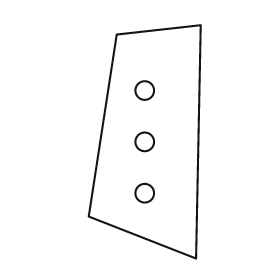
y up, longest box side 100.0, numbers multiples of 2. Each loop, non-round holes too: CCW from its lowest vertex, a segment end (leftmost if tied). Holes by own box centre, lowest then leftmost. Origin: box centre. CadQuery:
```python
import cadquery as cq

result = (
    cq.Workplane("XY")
    .moveTo(22.0, -50.0)
    .lineTo(24.0, 50.0)
    .lineTo(-12.0, 46.0)
    .lineTo(-24.0, -32.0)
    .close()
    .moveTo(0.0, -22.0)
    .circle(4.0)
    .moveTo(0.0, 0.0)
    .circle(4.0)
    .moveTo(0.0, 22.0)
    .circle(4.0)
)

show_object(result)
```